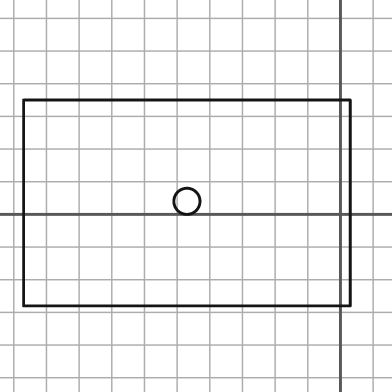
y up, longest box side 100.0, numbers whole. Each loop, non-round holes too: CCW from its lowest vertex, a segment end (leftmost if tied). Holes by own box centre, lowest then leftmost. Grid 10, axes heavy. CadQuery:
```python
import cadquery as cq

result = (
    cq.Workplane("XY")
    .moveTo(-97.0, -28.0)
    .lineTo(3.0, -28.0)
    .lineTo(3.0, 35.0)
    .lineTo(-97.0, 35.0)
    .close()
    .moveTo(-47.0, 4.0)
    .circle(4.0)
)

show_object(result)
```